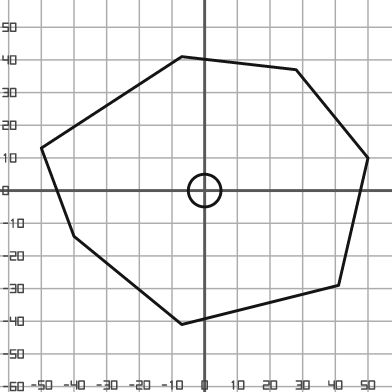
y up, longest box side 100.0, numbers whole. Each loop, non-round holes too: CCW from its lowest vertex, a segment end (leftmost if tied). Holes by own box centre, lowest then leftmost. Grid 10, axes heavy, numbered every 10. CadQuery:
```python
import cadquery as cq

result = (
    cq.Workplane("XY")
    .moveTo(-7.0, -41.0)
    .lineTo(41.0, -29.0)
    .lineTo(50.0, 10.0)
    .lineTo(28.0, 37.0)
    .lineTo(-7.0, 41.0)
    .lineTo(-50.0, 13.0)
    .lineTo(-40.0, -14.0)
    .close()
    .moveTo(0.0, 0.0)
    .circle(5.0)
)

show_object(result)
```